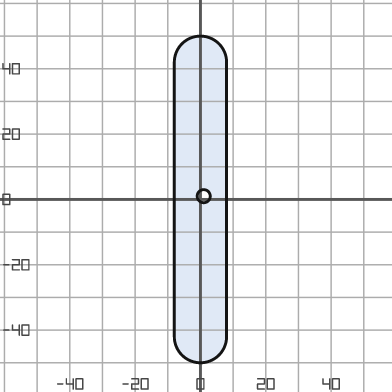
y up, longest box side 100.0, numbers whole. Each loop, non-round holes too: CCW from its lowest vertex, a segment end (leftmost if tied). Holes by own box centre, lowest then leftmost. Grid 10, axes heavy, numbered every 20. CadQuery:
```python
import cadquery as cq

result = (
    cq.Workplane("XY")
    .moveTo(-8.0, -42.0)
    .threePointArc((0.0, -50.0), (8.0, -42.0))
    .lineTo(8.0, 42.0)
    .threePointArc((0.0, 50.0), (-8.0, 42.0))
    .close()
    .moveTo(1.0, 1.0)
    .circle(2.0)
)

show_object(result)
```